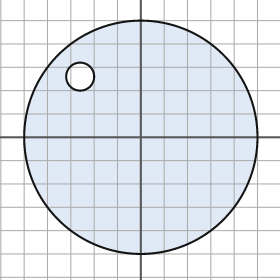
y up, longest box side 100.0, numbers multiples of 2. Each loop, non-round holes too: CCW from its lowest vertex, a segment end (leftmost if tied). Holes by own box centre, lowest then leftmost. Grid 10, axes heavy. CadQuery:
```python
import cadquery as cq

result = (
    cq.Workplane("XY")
    .moveTo(0.0, 0.0)
    .circle(50.0)
    .moveTo(-26.0, 26.0)
    .circle(6.0)
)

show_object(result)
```